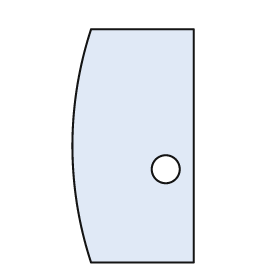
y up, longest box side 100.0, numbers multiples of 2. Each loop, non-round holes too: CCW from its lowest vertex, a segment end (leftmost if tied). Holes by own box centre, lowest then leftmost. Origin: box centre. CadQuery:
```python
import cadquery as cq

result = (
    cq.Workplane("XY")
    .moveTo(-18.0, -50.0)
    .lineTo(26.0, -50.0)
    .lineTo(26.0, 50.0)
    .lineTo(-18.0, 50.0)
    .threePointArc((-26.0, 0.0), (-18.0, -50.0))
    .close()
    .moveTo(14.0, -10.0)
    .circle(6.0)
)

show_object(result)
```